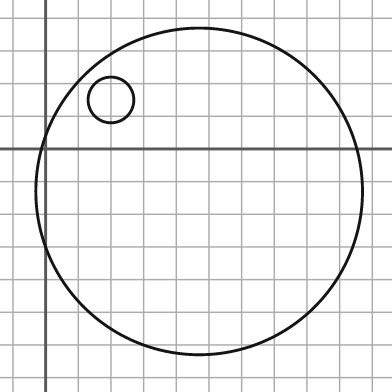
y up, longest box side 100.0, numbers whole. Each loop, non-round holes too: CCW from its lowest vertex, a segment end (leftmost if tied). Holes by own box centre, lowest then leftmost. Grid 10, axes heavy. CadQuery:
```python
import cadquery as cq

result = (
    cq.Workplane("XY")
    .moveTo(47.0, -13.0)
    .circle(50.0)
    .moveTo(20.0, 15.0)
    .circle(7.0)
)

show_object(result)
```